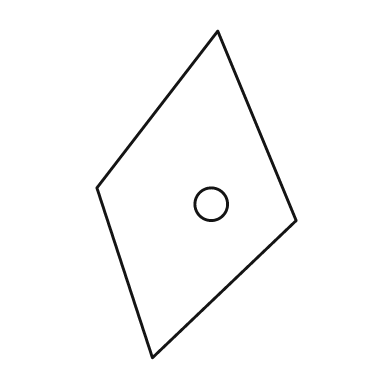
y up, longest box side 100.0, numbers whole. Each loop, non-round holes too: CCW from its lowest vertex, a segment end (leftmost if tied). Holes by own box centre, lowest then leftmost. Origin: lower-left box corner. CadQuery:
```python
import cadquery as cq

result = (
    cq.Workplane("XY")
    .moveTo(17.0, 0.0)
    .lineTo(61.0, 42.0)
    .lineTo(37.0, 100.0)
    .lineTo(0.0, 52.0)
    .close()
    .moveTo(35.0, 47.0)
    .circle(5.0)
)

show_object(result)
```